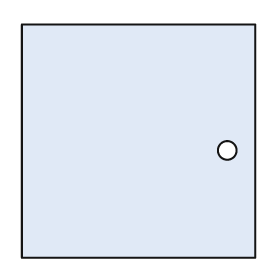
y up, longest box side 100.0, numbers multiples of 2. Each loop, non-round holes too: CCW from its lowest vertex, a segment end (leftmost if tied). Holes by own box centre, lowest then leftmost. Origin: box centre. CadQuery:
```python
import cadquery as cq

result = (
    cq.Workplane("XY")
    .moveTo(-50.0, -50.0)
    .lineTo(50.0, -50.0)
    .lineTo(50.0, 50.0)
    .lineTo(-50.0, 50.0)
    .close()
    .moveTo(38.0, -4.0)
    .circle(4.0)
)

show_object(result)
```